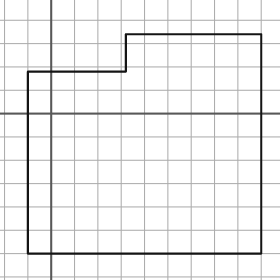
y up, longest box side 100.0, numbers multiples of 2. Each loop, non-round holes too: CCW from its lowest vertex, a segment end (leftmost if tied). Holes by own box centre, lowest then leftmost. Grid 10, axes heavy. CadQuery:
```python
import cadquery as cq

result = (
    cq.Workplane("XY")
    .moveTo(-10.0, -60.0)
    .lineTo(90.0, -60.0)
    .lineTo(90.0, 34.0)
    .lineTo(32.0, 34.0)
    .lineTo(32.0, 18.0)
    .lineTo(-10.0, 18.0)
    .close()
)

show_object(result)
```